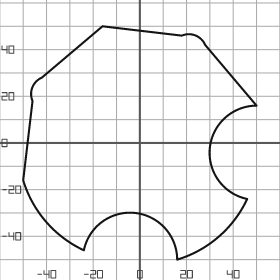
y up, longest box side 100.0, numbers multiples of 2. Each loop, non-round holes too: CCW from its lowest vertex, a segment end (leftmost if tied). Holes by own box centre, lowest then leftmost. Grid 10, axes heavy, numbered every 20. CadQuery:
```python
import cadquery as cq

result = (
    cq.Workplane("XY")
    .moveTo(16.0, -50.0)
    .threePointArc((34.0, -40.0), (46.0, -24.0))
    .threePointArc((30.0, -2.0), (50.0, 16.0))
    .lineTo(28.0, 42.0)
    .threePointArc((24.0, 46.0), (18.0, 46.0))
    .lineTo(-16.0, 50.0)
    .lineTo(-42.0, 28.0)
    .threePointArc((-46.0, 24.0), (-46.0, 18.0))
    .lineTo(-50.0, -16.0)
    .threePointArc((-40.0, -34.0), (-24.0, -46.0))
    .threePointArc((-2.0, -30.0), (16.0, -50.0))
    .close()
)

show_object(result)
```